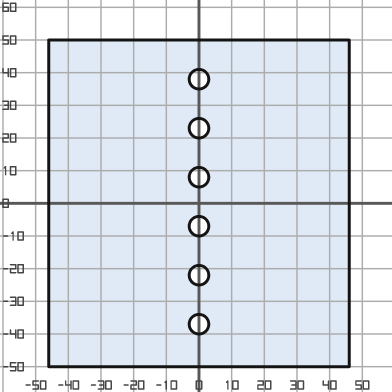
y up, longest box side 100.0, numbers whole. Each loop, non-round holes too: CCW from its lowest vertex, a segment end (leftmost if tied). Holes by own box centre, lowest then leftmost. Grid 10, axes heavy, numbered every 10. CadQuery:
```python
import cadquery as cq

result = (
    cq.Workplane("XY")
    .moveTo(-46.0, -50.0)
    .lineTo(46.0, -50.0)
    .lineTo(46.0, 50.0)
    .lineTo(-46.0, 50.0)
    .close()
    .moveTo(0.0, -37.0)
    .circle(3.0)
    .moveTo(0.0, -22.0)
    .circle(3.0)
    .moveTo(0.0, -7.0)
    .circle(3.0)
    .moveTo(0.0, 8.0)
    .circle(3.0)
    .moveTo(0.0, 23.0)
    .circle(3.0)
    .moveTo(0.0, 38.0)
    .circle(3.0)
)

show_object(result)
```